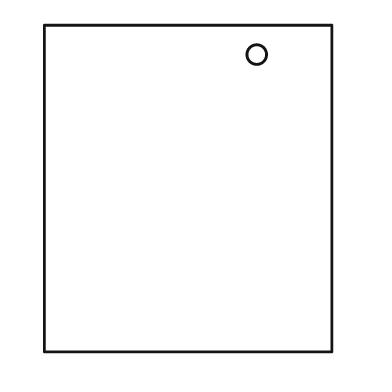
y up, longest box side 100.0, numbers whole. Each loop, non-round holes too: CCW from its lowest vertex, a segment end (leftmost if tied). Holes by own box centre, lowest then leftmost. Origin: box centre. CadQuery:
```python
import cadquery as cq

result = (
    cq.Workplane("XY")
    .moveTo(-44.0, -50.0)
    .lineTo(44.0, -50.0)
    .lineTo(44.0, 50.0)
    .lineTo(-44.0, 50.0)
    .close()
    .moveTo(21.0, 41.0)
    .circle(3.0)
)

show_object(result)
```